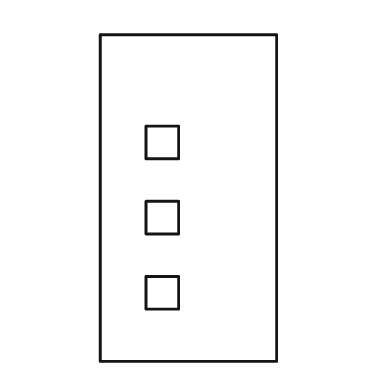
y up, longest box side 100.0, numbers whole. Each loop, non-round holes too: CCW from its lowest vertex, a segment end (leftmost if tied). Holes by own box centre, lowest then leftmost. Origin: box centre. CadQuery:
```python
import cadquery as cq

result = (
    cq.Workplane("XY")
    .moveTo(-27.0, -50.0)
    .lineTo(27.0, -50.0)
    .lineTo(27.0, 50.0)
    .lineTo(-27.0, 50.0)
    .close()
    .moveTo(-13.0, -34.0)
    .lineTo(-3.0, -34.0)
    .lineTo(-3.0, -24.0)
    .lineTo(-13.0, -24.0)
    .close()
    .moveTo(-13.0, -11.0)
    .lineTo(-3.0, -11.0)
    .lineTo(-3.0, -1.0)
    .lineTo(-13.0, -1.0)
    .close()
    .moveTo(-13.0, 12.0)
    .lineTo(-3.0, 12.0)
    .lineTo(-3.0, 22.0)
    .lineTo(-13.0, 22.0)
    .close()
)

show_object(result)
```